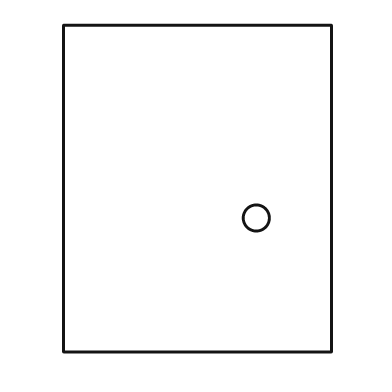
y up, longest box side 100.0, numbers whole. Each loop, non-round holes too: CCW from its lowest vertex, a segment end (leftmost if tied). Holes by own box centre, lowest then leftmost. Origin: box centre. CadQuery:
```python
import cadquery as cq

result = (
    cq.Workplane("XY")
    .moveTo(-41.0, -50.0)
    .lineTo(41.0, -50.0)
    .lineTo(41.0, 50.0)
    .lineTo(-41.0, 50.0)
    .close()
    .moveTo(18.0, -9.0)
    .circle(4.0)
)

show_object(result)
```